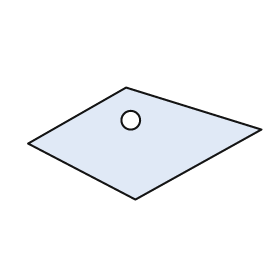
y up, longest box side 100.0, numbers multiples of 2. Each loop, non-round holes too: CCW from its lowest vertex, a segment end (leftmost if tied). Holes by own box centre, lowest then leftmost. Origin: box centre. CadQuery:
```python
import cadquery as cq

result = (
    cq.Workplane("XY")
    .moveTo(-4.0, -24.0)
    .lineTo(50.0, 6.0)
    .lineTo(-8.0, 24.0)
    .lineTo(-50.0, 0.0)
    .close()
    .moveTo(-6.0, 10.0)
    .circle(4.0)
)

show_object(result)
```